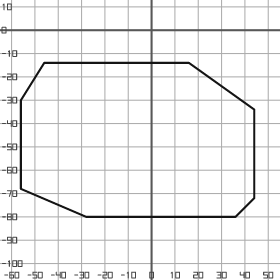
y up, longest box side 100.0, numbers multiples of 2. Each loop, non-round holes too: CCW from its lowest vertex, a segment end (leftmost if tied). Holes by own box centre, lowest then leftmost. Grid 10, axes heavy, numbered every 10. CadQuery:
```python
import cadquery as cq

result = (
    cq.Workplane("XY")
    .moveTo(-28.0, -80.0)
    .lineTo(36.0, -80.0)
    .lineTo(44.0, -72.0)
    .lineTo(44.0, -34.0)
    .lineTo(16.0, -14.0)
    .lineTo(-46.0, -14.0)
    .lineTo(-56.0, -30.0)
    .lineTo(-56.0, -68.0)
    .close()
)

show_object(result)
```